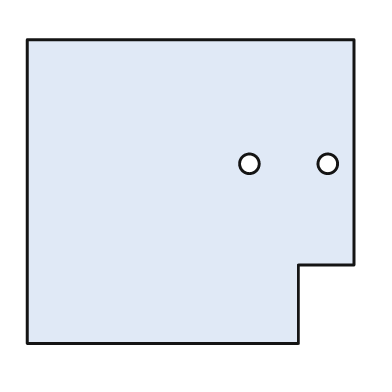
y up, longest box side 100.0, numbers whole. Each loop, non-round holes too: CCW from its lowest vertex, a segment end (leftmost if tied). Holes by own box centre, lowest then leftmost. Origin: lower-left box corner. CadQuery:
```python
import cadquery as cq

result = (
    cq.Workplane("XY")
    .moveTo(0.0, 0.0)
    .lineTo(83.0, 0.0)
    .lineTo(83.0, 24.0)
    .lineTo(100.0, 24.0)
    .lineTo(100.0, 93.0)
    .lineTo(0.0, 93.0)
    .close()
    .moveTo(68.0, 55.0)
    .circle(3.0)
    .moveTo(92.0, 55.0)
    .circle(3.0)
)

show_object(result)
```